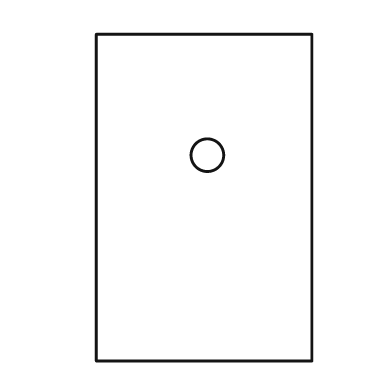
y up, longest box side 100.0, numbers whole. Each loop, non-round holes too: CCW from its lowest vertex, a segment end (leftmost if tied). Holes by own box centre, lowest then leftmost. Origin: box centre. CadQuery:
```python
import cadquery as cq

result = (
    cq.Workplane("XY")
    .moveTo(-33.0, -50.0)
    .lineTo(33.0, -50.0)
    .lineTo(33.0, 50.0)
    .lineTo(-33.0, 50.0)
    .close()
    .moveTo(1.0, 13.0)
    .circle(5.0)
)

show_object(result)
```